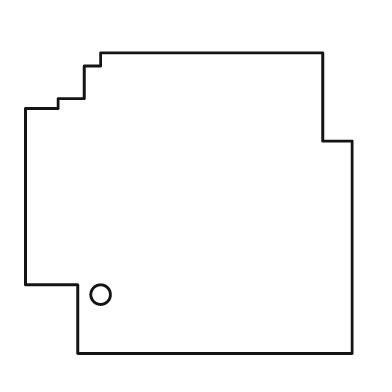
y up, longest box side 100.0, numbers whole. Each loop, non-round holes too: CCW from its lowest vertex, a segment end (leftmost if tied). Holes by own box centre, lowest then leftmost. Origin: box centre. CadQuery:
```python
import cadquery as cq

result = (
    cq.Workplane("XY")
    .moveTo(-34.0, -46.0)
    .lineTo(50.0, -46.0)
    .lineTo(50.0, 19.0)
    .lineTo(41.0, 19.0)
    .lineTo(41.0, 46.0)
    .lineTo(-27.0, 46.0)
    .lineTo(-27.0, 42.0)
    .lineTo(-32.0, 42.0)
    .lineTo(-32.0, 32.0)
    .lineTo(-40.0, 32.0)
    .lineTo(-40.0, 29.0)
    .lineTo(-50.0, 29.0)
    .lineTo(-50.0, -25.0)
    .lineTo(-34.0, -25.0)
    .close()
    .moveTo(-27.0, -28.0)
    .circle(3.0)
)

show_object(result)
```